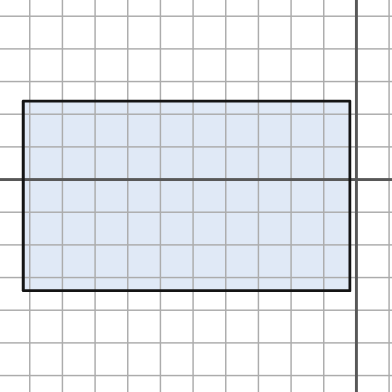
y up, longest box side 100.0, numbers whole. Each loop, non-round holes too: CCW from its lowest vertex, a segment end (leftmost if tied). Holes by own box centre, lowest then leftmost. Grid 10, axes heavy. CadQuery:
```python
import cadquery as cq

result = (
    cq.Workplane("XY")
    .moveTo(-102.0, -34.0)
    .lineTo(-2.0, -34.0)
    .lineTo(-2.0, 24.0)
    .lineTo(-102.0, 24.0)
    .close()
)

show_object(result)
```